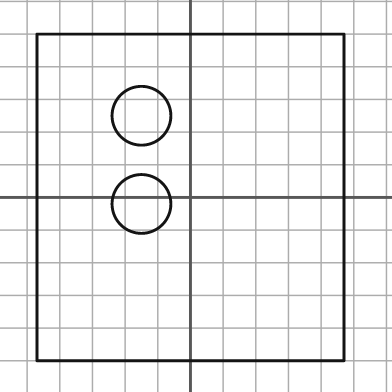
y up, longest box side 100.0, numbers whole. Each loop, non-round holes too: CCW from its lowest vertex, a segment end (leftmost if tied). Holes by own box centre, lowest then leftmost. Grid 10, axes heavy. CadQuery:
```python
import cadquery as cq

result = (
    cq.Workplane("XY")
    .moveTo(-47.0, -50.0)
    .lineTo(47.0, -50.0)
    .lineTo(47.0, 50.0)
    .lineTo(-47.0, 50.0)
    .close()
    .moveTo(-15.0, -2.0)
    .circle(9.0)
    .moveTo(-15.0, 25.0)
    .circle(9.0)
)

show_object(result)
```